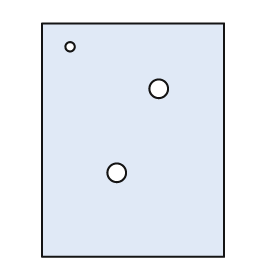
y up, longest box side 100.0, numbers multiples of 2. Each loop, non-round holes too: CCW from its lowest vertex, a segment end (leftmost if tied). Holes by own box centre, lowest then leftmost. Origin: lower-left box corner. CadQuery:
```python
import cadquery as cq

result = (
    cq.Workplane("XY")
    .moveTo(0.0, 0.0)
    .lineTo(78.0, 0.0)
    .lineTo(78.0, 100.0)
    .lineTo(0.0, 100.0)
    .close()
    .moveTo(32.0, 36.0)
    .circle(4.0)
    .moveTo(50.0, 72.0)
    .circle(4.0)
    .moveTo(12.0, 90.0)
    .circle(2.0)
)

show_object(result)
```